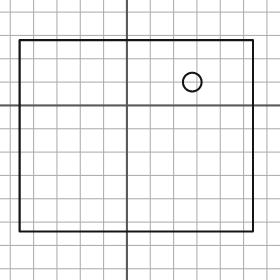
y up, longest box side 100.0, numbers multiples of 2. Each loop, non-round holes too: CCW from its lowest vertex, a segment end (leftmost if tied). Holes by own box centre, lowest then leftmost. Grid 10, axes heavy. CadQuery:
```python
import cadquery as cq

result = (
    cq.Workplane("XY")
    .moveTo(-46.0, -54.0)
    .lineTo(54.0, -54.0)
    .lineTo(54.0, 28.0)
    .lineTo(-46.0, 28.0)
    .close()
    .moveTo(28.0, 10.0)
    .circle(4.0)
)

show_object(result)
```